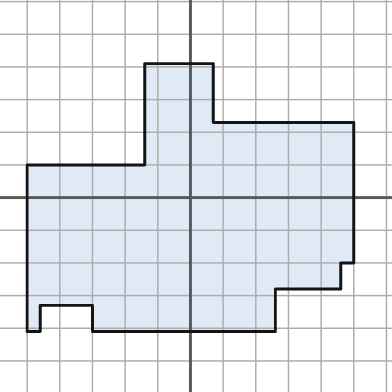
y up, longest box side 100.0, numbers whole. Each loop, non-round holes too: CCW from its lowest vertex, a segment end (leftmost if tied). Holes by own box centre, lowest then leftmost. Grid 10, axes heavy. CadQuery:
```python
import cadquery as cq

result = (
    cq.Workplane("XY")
    .moveTo(-50.0, -41.0)
    .lineTo(-46.0, -41.0)
    .lineTo(-46.0, -33.0)
    .lineTo(-30.0, -33.0)
    .lineTo(-30.0, -41.0)
    .lineTo(26.0, -41.0)
    .lineTo(26.0, -28.0)
    .lineTo(46.0, -28.0)
    .lineTo(46.0, -20.0)
    .lineTo(50.0, -20.0)
    .lineTo(50.0, 23.0)
    .lineTo(7.0, 23.0)
    .lineTo(7.0, 41.0)
    .lineTo(-14.0, 41.0)
    .lineTo(-14.0, 10.0)
    .lineTo(-50.0, 10.0)
    .close()
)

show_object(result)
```